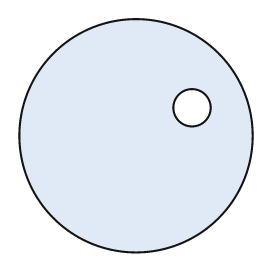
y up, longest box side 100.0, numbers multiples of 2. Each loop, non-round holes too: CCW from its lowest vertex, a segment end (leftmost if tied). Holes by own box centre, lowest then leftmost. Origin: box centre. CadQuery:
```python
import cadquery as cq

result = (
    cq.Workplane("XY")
    .moveTo(0.0, 0.0)
    .circle(50.0)
    .moveTo(24.0, 12.0)
    .circle(8.0)
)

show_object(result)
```